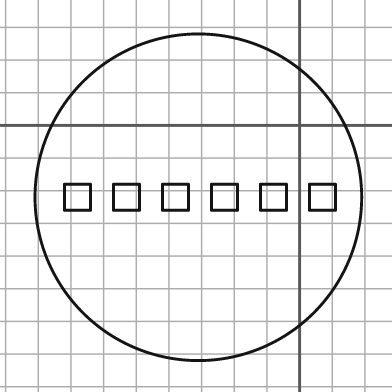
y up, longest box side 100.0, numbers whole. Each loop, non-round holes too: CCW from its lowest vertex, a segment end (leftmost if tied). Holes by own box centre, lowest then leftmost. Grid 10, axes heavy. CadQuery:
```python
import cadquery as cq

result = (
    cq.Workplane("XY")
    .moveTo(-31.0, -22.0)
    .circle(50.0)
    .moveTo(-72.0, -26.0)
    .lineTo(-64.0, -26.0)
    .lineTo(-64.0, -18.0)
    .lineTo(-72.0, -18.0)
    .close()
    .moveTo(-57.0, -26.0)
    .lineTo(-49.0, -26.0)
    .lineTo(-49.0, -18.0)
    .lineTo(-57.0, -18.0)
    .close()
    .moveTo(-42.0, -26.0)
    .lineTo(-34.0, -26.0)
    .lineTo(-34.0, -18.0)
    .lineTo(-42.0, -18.0)
    .close()
    .moveTo(-27.0, -26.0)
    .lineTo(-19.0, -26.0)
    .lineTo(-19.0, -18.0)
    .lineTo(-27.0, -18.0)
    .close()
    .moveTo(-12.0, -26.0)
    .lineTo(-4.0, -26.0)
    .lineTo(-4.0, -18.0)
    .lineTo(-12.0, -18.0)
    .close()
    .moveTo(3.0, -26.0)
    .lineTo(11.0, -26.0)
    .lineTo(11.0, -18.0)
    .lineTo(3.0, -18.0)
    .close()
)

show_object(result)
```